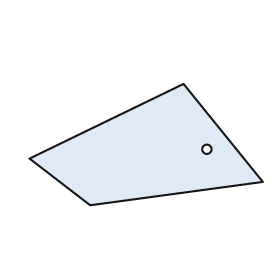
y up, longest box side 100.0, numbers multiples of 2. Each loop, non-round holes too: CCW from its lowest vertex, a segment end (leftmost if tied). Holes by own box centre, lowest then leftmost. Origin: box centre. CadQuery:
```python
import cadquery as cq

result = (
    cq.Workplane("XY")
    .moveTo(-24.0, -26.0)
    .lineTo(50.0, -16.0)
    .lineTo(16.0, 26.0)
    .lineTo(-50.0, -6.0)
    .close()
    .moveTo(26.0, -2.0)
    .circle(2.0)
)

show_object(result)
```